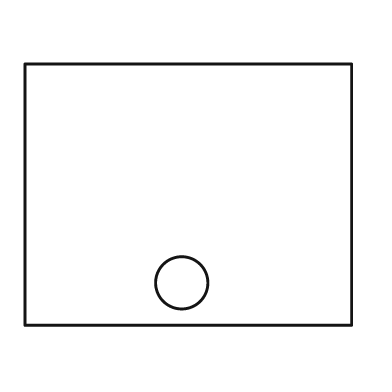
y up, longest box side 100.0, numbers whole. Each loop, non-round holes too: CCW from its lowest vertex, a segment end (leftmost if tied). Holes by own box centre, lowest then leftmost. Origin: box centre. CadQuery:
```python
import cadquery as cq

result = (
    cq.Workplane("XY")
    .moveTo(-50.0, -40.0)
    .lineTo(50.0, -40.0)
    .lineTo(50.0, 40.0)
    .lineTo(-50.0, 40.0)
    .close()
    .moveTo(-2.0, -27.0)
    .circle(8.0)
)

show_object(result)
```